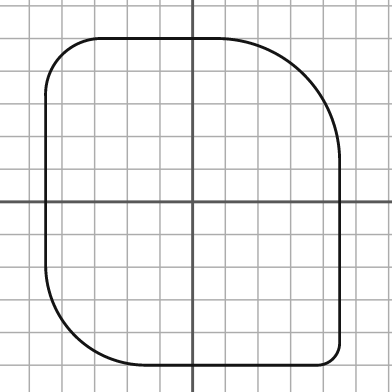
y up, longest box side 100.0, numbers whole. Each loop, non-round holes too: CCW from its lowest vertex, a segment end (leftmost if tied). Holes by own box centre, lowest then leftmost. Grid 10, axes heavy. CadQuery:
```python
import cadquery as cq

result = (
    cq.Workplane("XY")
    .moveTo(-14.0, -50.0)
    .lineTo(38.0, -50.0)
    .threePointArc((43.0, -48.0), (45.0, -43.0))
    .lineTo(45.0, 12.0)
    .threePointArc((34.0, 39.0), (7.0, 50.0))
    .lineTo(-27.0, 50.0)
    .threePointArc((-40.0, 45.0), (-45.0, 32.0))
    .lineTo(-45.0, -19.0)
    .threePointArc((-36.0, -41.0), (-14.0, -50.0))
    .close()
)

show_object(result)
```